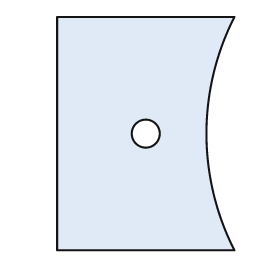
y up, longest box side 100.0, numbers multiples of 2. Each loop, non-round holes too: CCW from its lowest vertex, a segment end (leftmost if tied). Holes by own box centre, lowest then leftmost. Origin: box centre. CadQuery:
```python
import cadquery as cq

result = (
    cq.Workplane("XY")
    .moveTo(-38.0, -50.0)
    .lineTo(38.0, -50.0)
    .threePointArc((26.0, 0.0), (38.0, 50.0))
    .lineTo(-38.0, 50.0)
    .close()
    .moveTo(0.0, 0.0)
    .circle(6.0)
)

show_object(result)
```